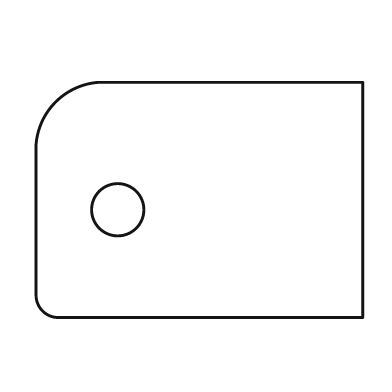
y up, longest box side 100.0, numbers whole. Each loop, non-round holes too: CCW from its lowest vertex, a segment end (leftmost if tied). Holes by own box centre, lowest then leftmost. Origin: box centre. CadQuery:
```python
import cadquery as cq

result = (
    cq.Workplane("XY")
    .moveTo(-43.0, -36.0)
    .lineTo(50.0, -36.0)
    .lineTo(50.0, 36.0)
    .lineTo(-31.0, 36.0)
    .threePointArc((-44.0, 30.0), (-50.0, 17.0))
    .lineTo(-50.0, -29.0)
    .threePointArc((-48.0, -34.0), (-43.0, -36.0))
    .close()
    .moveTo(-25.0, -3.0)
    .circle(8.0)
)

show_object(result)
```